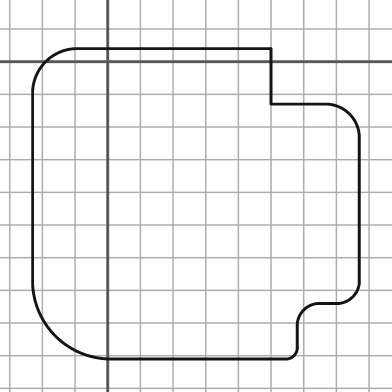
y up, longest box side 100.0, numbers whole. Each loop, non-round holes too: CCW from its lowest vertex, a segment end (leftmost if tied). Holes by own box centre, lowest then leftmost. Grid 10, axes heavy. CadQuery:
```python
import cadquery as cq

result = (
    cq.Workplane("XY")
    .moveTo(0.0, -91.0)
    .lineTo(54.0, -91.0)
    .threePointArc((57.0, -90.0), (58.0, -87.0))
    .lineTo(58.0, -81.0)
    .threePointArc((60.0, -76.0), (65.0, -74.0))
    .lineTo(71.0, -74.0)
    .threePointArc((75.0, -72.0), (77.0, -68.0))
    .lineTo(77.0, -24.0)
    .threePointArc((74.0, -16.0), (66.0, -13.0))
    .lineTo(50.0, -13.0)
    .lineTo(50.0, 4.0)
    .lineTo(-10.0, 4.0)
    .threePointArc((-19.0, 0.0), (-23.0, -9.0))
    .lineTo(-23.0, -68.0)
    .threePointArc((-16.0, -84.0), (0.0, -91.0))
    .close()
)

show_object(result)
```